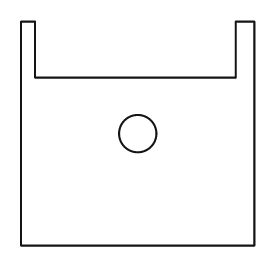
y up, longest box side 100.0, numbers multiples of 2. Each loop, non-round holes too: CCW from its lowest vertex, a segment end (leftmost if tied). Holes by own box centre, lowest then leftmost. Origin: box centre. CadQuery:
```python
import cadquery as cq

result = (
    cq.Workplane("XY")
    .moveTo(-50.0, -48.0)
    .lineTo(50.0, -48.0)
    .lineTo(50.0, 48.0)
    .lineTo(42.0, 48.0)
    .lineTo(42.0, 24.0)
    .lineTo(-44.0, 24.0)
    .lineTo(-44.0, 48.0)
    .lineTo(-50.0, 48.0)
    .close()
    .moveTo(0.0, 0.0)
    .circle(8.0)
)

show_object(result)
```